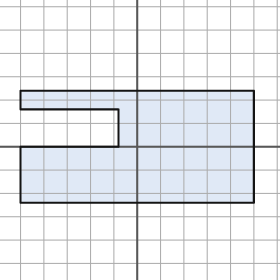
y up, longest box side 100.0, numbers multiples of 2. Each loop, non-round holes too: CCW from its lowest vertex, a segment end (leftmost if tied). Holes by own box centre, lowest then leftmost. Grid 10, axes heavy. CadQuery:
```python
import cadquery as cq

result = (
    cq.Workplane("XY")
    .moveTo(-50.0, -24.0)
    .lineTo(50.0, -24.0)
    .lineTo(50.0, 24.0)
    .lineTo(-50.0, 24.0)
    .lineTo(-50.0, 16.0)
    .lineTo(-8.0, 16.0)
    .lineTo(-8.0, 0.0)
    .lineTo(-50.0, 0.0)
    .close()
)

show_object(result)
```